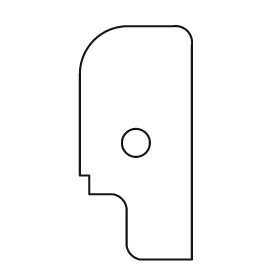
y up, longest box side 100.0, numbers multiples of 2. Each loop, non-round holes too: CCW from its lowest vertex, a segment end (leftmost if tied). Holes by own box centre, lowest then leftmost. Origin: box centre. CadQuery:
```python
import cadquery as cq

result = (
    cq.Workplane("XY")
    .moveTo(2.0, -50.0)
    .lineTo(24.0, -50.0)
    .lineTo(24.0, 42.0)
    .threePointArc((22.0, 48.0), (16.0, 50.0))
    .lineTo(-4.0, 50.0)
    .threePointArc((-18.0, 44.0), (-24.0, 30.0))
    .lineTo(-24.0, -14.0)
    .lineTo(-20.0, -14.0)
    .lineTo(-20.0, -22.0)
    .lineTo(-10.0, -22.0)
    .threePointArc((-6.0, -24.0), (-4.0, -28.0))
    .lineTo(-4.0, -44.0)
    .threePointArc((-2.0, -48.0), (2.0, -50.0))
    .close()
    .moveTo(0.0, 0.0)
    .circle(6.0)
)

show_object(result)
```